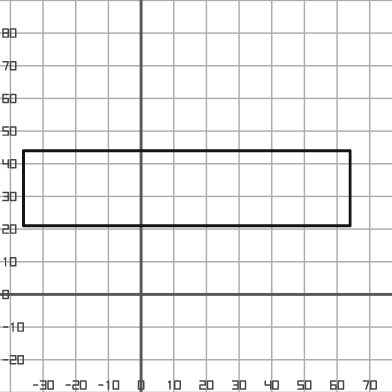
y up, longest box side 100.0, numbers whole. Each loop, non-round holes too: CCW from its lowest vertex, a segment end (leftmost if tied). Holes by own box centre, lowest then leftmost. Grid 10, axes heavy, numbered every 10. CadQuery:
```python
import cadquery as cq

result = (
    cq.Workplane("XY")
    .moveTo(-36.0, 21.0)
    .lineTo(64.0, 21.0)
    .lineTo(64.0, 44.0)
    .lineTo(-36.0, 44.0)
    .close()
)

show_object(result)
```